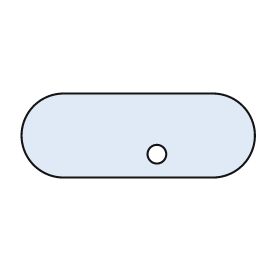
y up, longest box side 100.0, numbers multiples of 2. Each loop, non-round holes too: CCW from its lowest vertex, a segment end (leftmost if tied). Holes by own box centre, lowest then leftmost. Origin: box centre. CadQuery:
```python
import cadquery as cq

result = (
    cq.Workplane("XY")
    .moveTo(-32.0, -18.0)
    .lineTo(32.0, -18.0)
    .threePointArc((50.0, 0.0), (32.0, 18.0))
    .lineTo(-32.0, 18.0)
    .threePointArc((-50.0, 0.0), (-32.0, -18.0))
    .close()
    .moveTo(8.0, -8.0)
    .circle(4.0)
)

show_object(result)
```